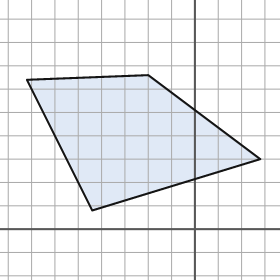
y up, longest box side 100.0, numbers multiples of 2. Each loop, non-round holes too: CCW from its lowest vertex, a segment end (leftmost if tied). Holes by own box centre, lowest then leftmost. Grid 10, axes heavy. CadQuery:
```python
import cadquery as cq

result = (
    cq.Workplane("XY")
    .moveTo(-44.0, 8.0)
    .lineTo(28.0, 30.0)
    .lineTo(-20.0, 66.0)
    .lineTo(-72.0, 64.0)
    .close()
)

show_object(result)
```